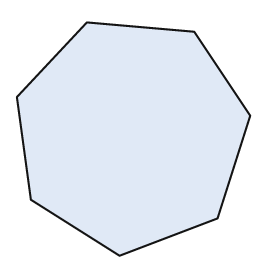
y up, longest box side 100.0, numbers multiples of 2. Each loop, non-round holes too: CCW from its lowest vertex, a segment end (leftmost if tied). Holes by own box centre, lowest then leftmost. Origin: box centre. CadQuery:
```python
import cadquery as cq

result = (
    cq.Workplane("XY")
    .moveTo(-6.0, -50.0)
    .lineTo(36.0, -34.0)
    .lineTo(50.0, 10.0)
    .lineTo(26.0, 46.0)
    .lineTo(-20.0, 50.0)
    .lineTo(-50.0, 18.0)
    .lineTo(-44.0, -26.0)
    .close()
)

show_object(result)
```